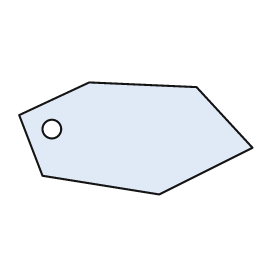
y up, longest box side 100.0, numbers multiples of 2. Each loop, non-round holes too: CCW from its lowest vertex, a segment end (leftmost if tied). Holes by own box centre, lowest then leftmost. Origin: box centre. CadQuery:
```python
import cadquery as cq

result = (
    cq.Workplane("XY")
    .moveTo(10.0, -24.0)
    .lineTo(50.0, -4.0)
    .lineTo(26.0, 22.0)
    .lineTo(-20.0, 24.0)
    .lineTo(-50.0, 10.0)
    .lineTo(-40.0, -16.0)
    .close()
    .moveTo(-36.0, 4.0)
    .circle(4.0)
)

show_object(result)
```